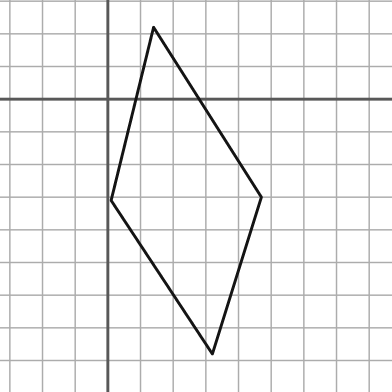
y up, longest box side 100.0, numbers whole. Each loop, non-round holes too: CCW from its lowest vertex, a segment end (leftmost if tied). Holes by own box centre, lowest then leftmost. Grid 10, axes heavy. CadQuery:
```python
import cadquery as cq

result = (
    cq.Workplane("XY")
    .moveTo(32.0, -78.0)
    .lineTo(47.0, -30.0)
    .lineTo(14.0, 22.0)
    .lineTo(1.0, -31.0)
    .close()
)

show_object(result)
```